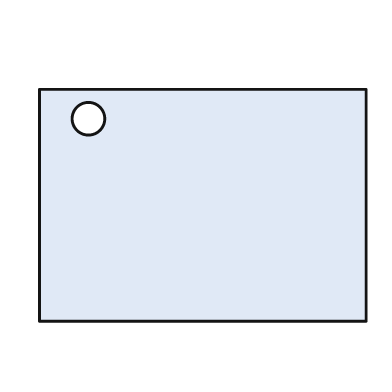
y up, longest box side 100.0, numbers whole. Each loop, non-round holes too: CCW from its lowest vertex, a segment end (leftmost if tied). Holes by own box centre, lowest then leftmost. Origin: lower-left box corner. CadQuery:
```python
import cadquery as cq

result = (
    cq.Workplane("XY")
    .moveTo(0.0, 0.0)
    .lineTo(100.0, 0.0)
    .lineTo(100.0, 71.0)
    .lineTo(0.0, 71.0)
    .close()
    .moveTo(15.0, 62.0)
    .circle(5.0)
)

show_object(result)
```